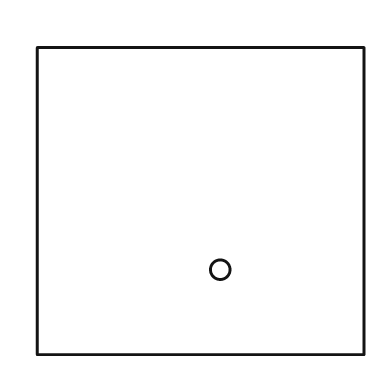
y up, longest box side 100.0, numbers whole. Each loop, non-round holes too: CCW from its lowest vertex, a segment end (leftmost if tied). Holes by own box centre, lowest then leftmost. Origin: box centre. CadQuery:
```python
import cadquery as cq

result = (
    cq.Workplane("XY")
    .moveTo(-50.0, -47.0)
    .lineTo(50.0, -47.0)
    .lineTo(50.0, 47.0)
    .lineTo(-50.0, 47.0)
    .close()
    .moveTo(6.0, -21.0)
    .circle(3.0)
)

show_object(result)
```